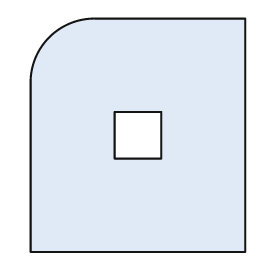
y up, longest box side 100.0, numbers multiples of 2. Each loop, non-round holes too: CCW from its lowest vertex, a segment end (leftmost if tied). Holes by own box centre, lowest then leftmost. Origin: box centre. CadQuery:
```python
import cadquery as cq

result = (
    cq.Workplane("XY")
    .moveTo(-46.0, -50.0)
    .lineTo(46.0, -50.0)
    .lineTo(46.0, 50.0)
    .lineTo(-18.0, 50.0)
    .threePointArc((-38.0, 42.0), (-46.0, 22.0))
    .close()
    .moveTo(-10.0, -10.0)
    .lineTo(10.0, -10.0)
    .lineTo(10.0, 10.0)
    .lineTo(-10.0, 10.0)
    .close()
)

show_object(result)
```